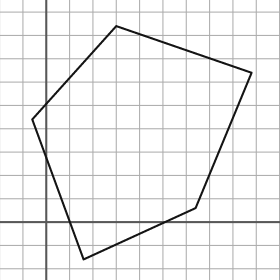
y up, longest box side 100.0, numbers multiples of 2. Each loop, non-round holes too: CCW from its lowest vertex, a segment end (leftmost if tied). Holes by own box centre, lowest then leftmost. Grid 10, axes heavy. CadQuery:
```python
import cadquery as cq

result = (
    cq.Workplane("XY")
    .moveTo(16.0, -16.0)
    .lineTo(64.0, 6.0)
    .lineTo(88.0, 64.0)
    .lineTo(30.0, 84.0)
    .lineTo(-6.0, 44.0)
    .close()
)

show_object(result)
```